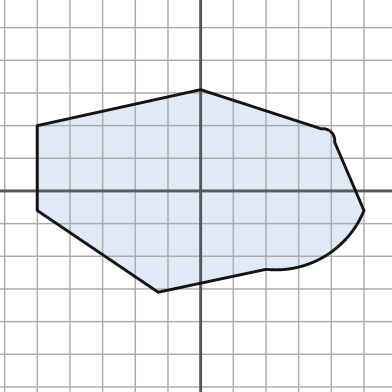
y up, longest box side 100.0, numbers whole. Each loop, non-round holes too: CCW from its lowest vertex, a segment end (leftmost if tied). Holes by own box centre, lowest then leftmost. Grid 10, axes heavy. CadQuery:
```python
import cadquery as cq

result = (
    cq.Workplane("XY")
    .moveTo(-13.0, -31.0)
    .lineTo(20.0, -24.0)
    .threePointArc((38.0, -20.0), (50.0, -6.0))
    .lineTo(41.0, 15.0)
    .threePointArc((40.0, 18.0), (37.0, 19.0))
    .lineTo(0.0, 31.0)
    .lineTo(-50.0, 20.0)
    .lineTo(-50.0, -6.0)
    .close()
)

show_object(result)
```